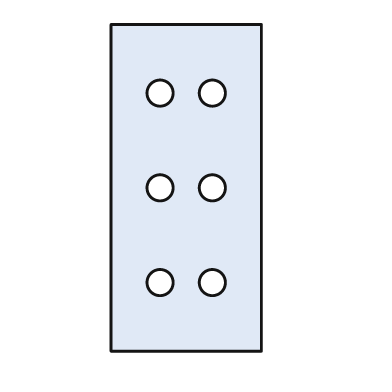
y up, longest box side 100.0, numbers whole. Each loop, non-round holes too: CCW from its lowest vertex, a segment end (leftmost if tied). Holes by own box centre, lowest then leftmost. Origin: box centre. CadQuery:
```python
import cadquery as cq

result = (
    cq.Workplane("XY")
    .moveTo(-23.0, -50.0)
    .lineTo(23.0, -50.0)
    .lineTo(23.0, 50.0)
    .lineTo(-23.0, 50.0)
    .close()
    .moveTo(-8.0, -29.0)
    .circle(4.0)
    .moveTo(8.0, -29.0)
    .circle(4.0)
    .moveTo(-8.0, 0.0)
    .circle(4.0)
    .moveTo(8.0, 0.0)
    .circle(4.0)
    .moveTo(-8.0, 29.0)
    .circle(4.0)
    .moveTo(8.0, 29.0)
    .circle(4.0)
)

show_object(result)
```